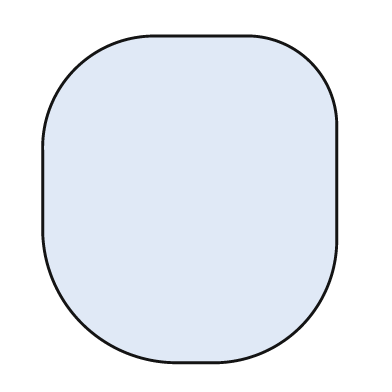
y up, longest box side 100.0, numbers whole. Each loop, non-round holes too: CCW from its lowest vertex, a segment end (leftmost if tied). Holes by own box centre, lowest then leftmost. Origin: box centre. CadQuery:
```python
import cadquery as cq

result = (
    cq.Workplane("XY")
    .moveTo(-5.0, -50.0)
    .lineTo(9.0, -50.0)
    .threePointArc((34.0, -39.0), (45.0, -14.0))
    .lineTo(45.0, 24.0)
    .threePointArc((37.0, 42.0), (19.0, 50.0))
    .lineTo(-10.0, 50.0)
    .threePointArc((-35.0, 40.0), (-45.0, 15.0))
    .lineTo(-45.0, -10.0)
    .threePointArc((-33.0, -38.0), (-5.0, -50.0))
    .close()
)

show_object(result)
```